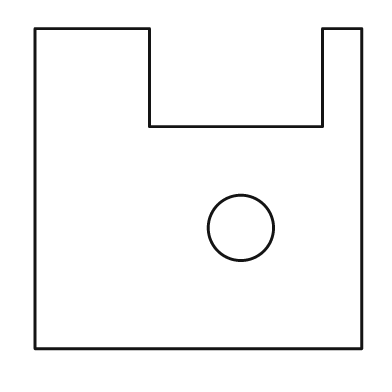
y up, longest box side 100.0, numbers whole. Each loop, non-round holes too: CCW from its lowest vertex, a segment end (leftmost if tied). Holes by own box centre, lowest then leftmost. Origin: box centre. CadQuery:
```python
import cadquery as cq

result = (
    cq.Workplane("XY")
    .moveTo(-50.0, -49.0)
    .lineTo(50.0, -49.0)
    .lineTo(50.0, 49.0)
    .lineTo(38.0, 49.0)
    .lineTo(38.0, 19.0)
    .lineTo(-15.0, 19.0)
    .lineTo(-15.0, 49.0)
    .lineTo(-50.0, 49.0)
    .close()
    .moveTo(13.0, -12.0)
    .circle(10.0)
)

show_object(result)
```